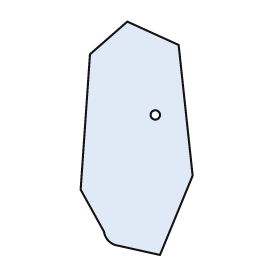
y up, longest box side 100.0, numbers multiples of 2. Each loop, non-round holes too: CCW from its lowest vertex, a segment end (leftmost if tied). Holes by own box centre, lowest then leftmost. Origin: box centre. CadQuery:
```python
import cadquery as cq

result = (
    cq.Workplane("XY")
    .moveTo(10.0, -50.0)
    .lineTo(24.0, -16.0)
    .lineTo(18.0, 40.0)
    .lineTo(-4.0, 50.0)
    .lineTo(-20.0, 36.0)
    .lineTo(-24.0, -22.0)
    .lineTo(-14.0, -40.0)
    .threePointArc((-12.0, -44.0), (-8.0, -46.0))
    .close()
    .moveTo(8.0, 10.0)
    .circle(2.0)
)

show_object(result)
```